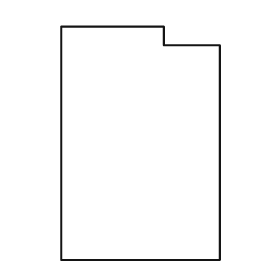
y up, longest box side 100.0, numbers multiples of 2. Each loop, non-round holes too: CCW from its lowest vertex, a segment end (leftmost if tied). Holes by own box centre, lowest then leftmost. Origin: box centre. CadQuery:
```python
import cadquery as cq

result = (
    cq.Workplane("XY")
    .moveTo(-34.0, -50.0)
    .lineTo(34.0, -50.0)
    .lineTo(34.0, 42.0)
    .lineTo(10.0, 42.0)
    .lineTo(10.0, 50.0)
    .lineTo(-34.0, 50.0)
    .close()
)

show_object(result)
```